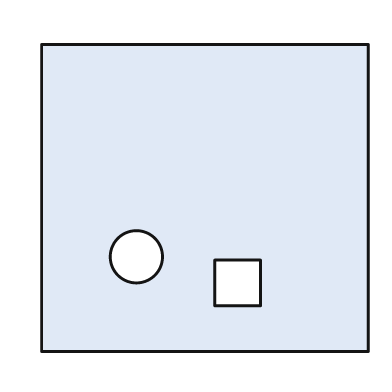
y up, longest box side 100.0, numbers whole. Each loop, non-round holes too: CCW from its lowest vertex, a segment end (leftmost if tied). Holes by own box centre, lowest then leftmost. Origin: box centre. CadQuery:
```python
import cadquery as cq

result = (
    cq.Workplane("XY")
    .moveTo(-50.0, -47.0)
    .lineTo(50.0, -47.0)
    .lineTo(50.0, 47.0)
    .lineTo(-50.0, 47.0)
    .close()
    .moveTo(3.0, -33.0)
    .lineTo(17.0, -33.0)
    .lineTo(17.0, -19.0)
    .lineTo(3.0, -19.0)
    .close()
    .moveTo(-21.0, -18.0)
    .circle(8.0)
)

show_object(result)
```